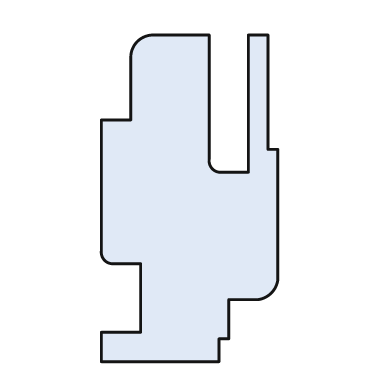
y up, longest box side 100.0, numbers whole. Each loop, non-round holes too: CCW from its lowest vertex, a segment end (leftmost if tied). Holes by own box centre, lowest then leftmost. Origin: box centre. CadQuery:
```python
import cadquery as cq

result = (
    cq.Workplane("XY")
    .moveTo(-27.0, -50.0)
    .lineTo(9.0, -50.0)
    .lineTo(9.0, -43.0)
    .lineTo(12.0, -43.0)
    .lineTo(12.0, -31.0)
    .lineTo(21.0, -31.0)
    .threePointArc((25.0, -29.0), (27.0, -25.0))
    .lineTo(27.0, 15.0)
    .lineTo(24.0, 15.0)
    .lineTo(24.0, 50.0)
    .lineTo(18.0, 50.0)
    .lineTo(18.0, 8.0)
    .lineTo(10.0, 8.0)
    .threePointArc((7.0, 9.0), (6.0, 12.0))
    .lineTo(6.0, 50.0)
    .lineTo(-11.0, 50.0)
    .threePointArc((-16.0, 48.0), (-18.0, 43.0))
    .lineTo(-18.0, 24.0)
    .lineTo(-27.0, 24.0)
    .lineTo(-27.0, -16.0)
    .threePointArc((-26.0, -19.0), (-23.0, -20.0))
    .lineTo(-15.0, -20.0)
    .lineTo(-15.0, -41.0)
    .lineTo(-27.0, -41.0)
    .close()
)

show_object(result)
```